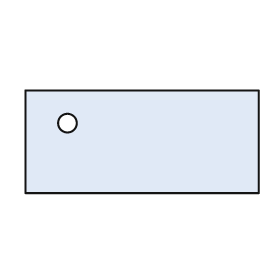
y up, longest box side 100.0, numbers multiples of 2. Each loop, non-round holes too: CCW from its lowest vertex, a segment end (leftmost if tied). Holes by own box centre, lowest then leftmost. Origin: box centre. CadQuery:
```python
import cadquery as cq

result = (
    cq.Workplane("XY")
    .moveTo(-50.0, -22.0)
    .lineTo(50.0, -22.0)
    .lineTo(50.0, 22.0)
    .lineTo(-50.0, 22.0)
    .close()
    .moveTo(-32.0, 8.0)
    .circle(4.0)
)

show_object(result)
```